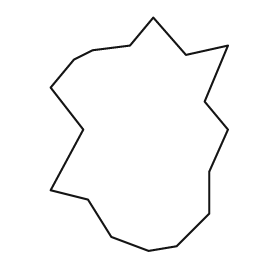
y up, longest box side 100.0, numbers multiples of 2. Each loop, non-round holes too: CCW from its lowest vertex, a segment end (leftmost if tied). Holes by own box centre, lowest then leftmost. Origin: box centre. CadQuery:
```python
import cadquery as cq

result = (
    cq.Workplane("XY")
    .moveTo(4.0, -50.0)
    .lineTo(16.0, -48.0)
    .lineTo(30.0, -34.0)
    .lineTo(30.0, -16.0)
    .lineTo(38.0, 2.0)
    .lineTo(28.0, 14.0)
    .lineTo(38.0, 38.0)
    .lineTo(20.0, 34.0)
    .lineTo(6.0, 50.0)
    .lineTo(-4.0, 38.0)
    .lineTo(-20.0, 36.0)
    .lineTo(-28.0, 32.0)
    .lineTo(-38.0, 20.0)
    .lineTo(-24.0, 2.0)
    .lineTo(-38.0, -24.0)
    .lineTo(-22.0, -28.0)
    .lineTo(-12.0, -44.0)
    .close()
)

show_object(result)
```